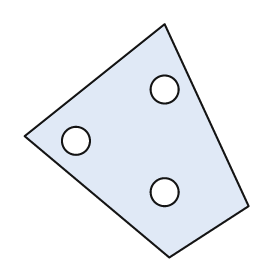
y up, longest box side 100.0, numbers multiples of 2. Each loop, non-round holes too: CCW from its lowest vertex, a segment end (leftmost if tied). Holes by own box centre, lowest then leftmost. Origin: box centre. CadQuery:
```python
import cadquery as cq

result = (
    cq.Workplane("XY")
    .moveTo(14.0, -50.0)
    .lineTo(48.0, -28.0)
    .lineTo(12.0, 50.0)
    .lineTo(-48.0, 2.0)
    .close()
    .moveTo(12.0, -22.0)
    .circle(6.0)
    .moveTo(-26.0, 0.0)
    .circle(6.0)
    .moveTo(12.0, 22.0)
    .circle(6.0)
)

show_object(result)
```